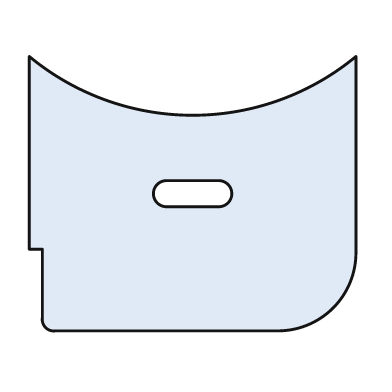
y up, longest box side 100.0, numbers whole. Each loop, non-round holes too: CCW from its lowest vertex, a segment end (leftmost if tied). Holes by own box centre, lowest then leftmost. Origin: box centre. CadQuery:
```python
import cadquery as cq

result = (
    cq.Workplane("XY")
    .moveTo(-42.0, -42.0)
    .lineTo(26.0, -42.0)
    .threePointArc((43.0, -35.0), (50.0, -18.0))
    .lineTo(50.0, 42.0)
    .threePointArc((0.0, 24.0), (-50.0, 42.0))
    .lineTo(-50.0, -17.0)
    .lineTo(-46.0, -17.0)
    .lineTo(-46.0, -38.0)
    .threePointArc((-45.0, -41.0), (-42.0, -42.0))
    .close()
    .moveTo(-8.0, -4.0)
    .lineTo(8.0, -4.0)
    .threePointArc((12.0, 0.0), (8.0, 4.0))
    .lineTo(-8.0, 4.0)
    .threePointArc((-12.0, 0.0), (-8.0, -4.0))
    .close()
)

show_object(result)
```